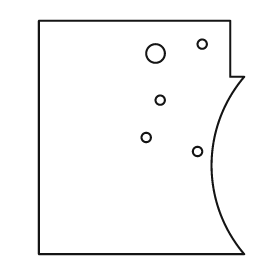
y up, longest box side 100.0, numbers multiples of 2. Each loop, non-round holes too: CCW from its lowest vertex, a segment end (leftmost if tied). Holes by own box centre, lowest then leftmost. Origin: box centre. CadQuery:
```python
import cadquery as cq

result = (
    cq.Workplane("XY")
    .moveTo(-44.0, -50.0)
    .lineTo(44.0, -50.0)
    .threePointArc((30.0, -12.0), (44.0, 26.0))
    .lineTo(38.0, 26.0)
    .lineTo(38.0, 50.0)
    .lineTo(-44.0, 50.0)
    .close()
    .moveTo(24.0, -6.0)
    .circle(2.0)
    .moveTo(2.0, 0.0)
    .circle(2.0)
    .moveTo(8.0, 16.0)
    .circle(2.0)
    .moveTo(6.0, 36.0)
    .circle(4.0)
    .moveTo(26.0, 40.0)
    .circle(2.0)
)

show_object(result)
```